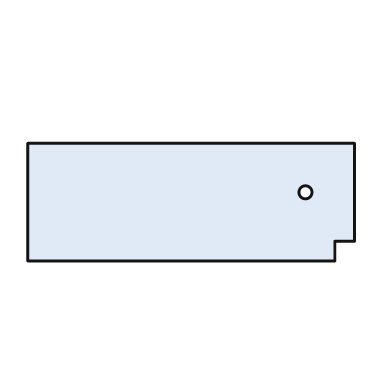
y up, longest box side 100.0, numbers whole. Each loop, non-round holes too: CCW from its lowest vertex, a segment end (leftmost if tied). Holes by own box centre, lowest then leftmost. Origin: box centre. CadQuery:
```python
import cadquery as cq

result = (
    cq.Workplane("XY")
    .moveTo(-50.0, -18.0)
    .lineTo(44.0, -18.0)
    .lineTo(44.0, -12.0)
    .lineTo(50.0, -12.0)
    .lineTo(50.0, 18.0)
    .lineTo(-50.0, 18.0)
    .close()
    .moveTo(35.0, 3.0)
    .circle(2.0)
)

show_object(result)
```